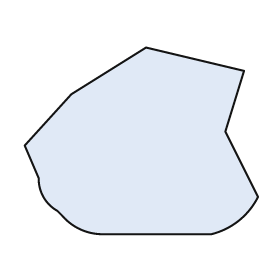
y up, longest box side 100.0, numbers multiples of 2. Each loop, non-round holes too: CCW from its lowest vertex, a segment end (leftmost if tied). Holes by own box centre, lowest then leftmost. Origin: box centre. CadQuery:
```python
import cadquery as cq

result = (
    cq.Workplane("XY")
    .moveTo(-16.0, -40.0)
    .lineTo(30.0, -40.0)
    .threePointArc((42.0, -34.0), (50.0, -24.0))
    .lineTo(36.0, 4.0)
    .lineTo(44.0, 30.0)
    .lineTo(2.0, 40.0)
    .lineTo(-30.0, 20.0)
    .lineTo(-50.0, -2.0)
    .lineTo(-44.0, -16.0)
    .threePointArc((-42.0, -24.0), (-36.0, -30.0))
    .lineTo(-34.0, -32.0)
    .threePointArc((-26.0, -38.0), (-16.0, -40.0))
    .close()
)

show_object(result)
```